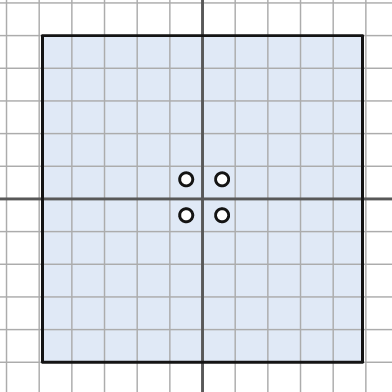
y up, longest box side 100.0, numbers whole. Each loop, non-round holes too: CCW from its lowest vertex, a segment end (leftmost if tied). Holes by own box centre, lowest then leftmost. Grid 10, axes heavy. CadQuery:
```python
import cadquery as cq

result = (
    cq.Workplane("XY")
    .moveTo(-49.0, -50.0)
    .lineTo(49.0, -50.0)
    .lineTo(49.0, 50.0)
    .lineTo(-49.0, 50.0)
    .close()
    .moveTo(-5.0, -5.0)
    .circle(2.0)
    .moveTo(6.0, -5.0)
    .circle(2.0)
    .moveTo(-5.0, 6.0)
    .circle(2.0)
    .moveTo(6.0, 6.0)
    .circle(2.0)
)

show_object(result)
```